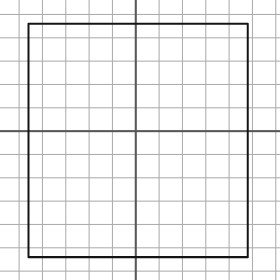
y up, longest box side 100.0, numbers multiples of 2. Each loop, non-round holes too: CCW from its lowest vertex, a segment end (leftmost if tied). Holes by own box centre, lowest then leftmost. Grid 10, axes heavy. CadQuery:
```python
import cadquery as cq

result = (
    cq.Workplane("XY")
    .moveTo(-46.0, -54.0)
    .lineTo(48.0, -54.0)
    .lineTo(48.0, 46.0)
    .lineTo(-46.0, 46.0)
    .close()
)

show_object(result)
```